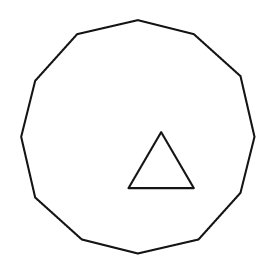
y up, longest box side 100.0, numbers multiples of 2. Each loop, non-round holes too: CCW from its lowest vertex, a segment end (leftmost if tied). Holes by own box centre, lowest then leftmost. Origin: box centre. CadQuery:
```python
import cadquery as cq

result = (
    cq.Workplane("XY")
    .moveTo(0.0, -50.0)
    .lineTo(26.0, -44.0)
    .lineTo(44.0, -24.0)
    .lineTo(50.0, 0.0)
    .lineTo(44.0, 26.0)
    .lineTo(24.0, 44.0)
    .lineTo(0.0, 50.0)
    .lineTo(-26.0, 44.0)
    .lineTo(-44.0, 24.0)
    .lineTo(-50.0, 0.0)
    .lineTo(-44.0, -26.0)
    .lineTo(-24.0, -44.0)
    .close()
    .moveTo(-4.0, -22.0)
    .lineTo(24.0, -22.0)
    .lineTo(10.0, 2.0)
    .close()
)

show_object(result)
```